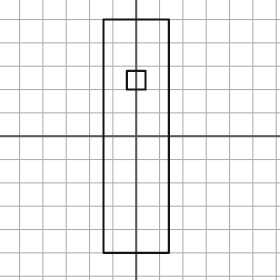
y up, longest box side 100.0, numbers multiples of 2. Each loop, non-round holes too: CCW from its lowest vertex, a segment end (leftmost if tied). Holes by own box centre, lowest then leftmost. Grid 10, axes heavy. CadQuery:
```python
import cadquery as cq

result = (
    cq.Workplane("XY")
    .moveTo(-14.0, -50.0)
    .lineTo(14.0, -50.0)
    .lineTo(14.0, 50.0)
    .lineTo(-14.0, 50.0)
    .close()
    .moveTo(-4.0, 20.0)
    .lineTo(4.0, 20.0)
    .lineTo(4.0, 28.0)
    .lineTo(-4.0, 28.0)
    .close()
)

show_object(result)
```